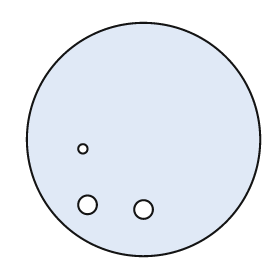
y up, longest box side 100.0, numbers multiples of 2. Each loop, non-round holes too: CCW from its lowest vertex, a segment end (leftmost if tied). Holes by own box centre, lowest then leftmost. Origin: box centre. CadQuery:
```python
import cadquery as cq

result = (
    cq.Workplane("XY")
    .moveTo(0.0, 0.0)
    .circle(50.0)
    .moveTo(0.0, -30.0)
    .circle(4.0)
    .moveTo(-24.0, -28.0)
    .circle(4.0)
    .moveTo(-26.0, -4.0)
    .circle(2.0)
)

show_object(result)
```